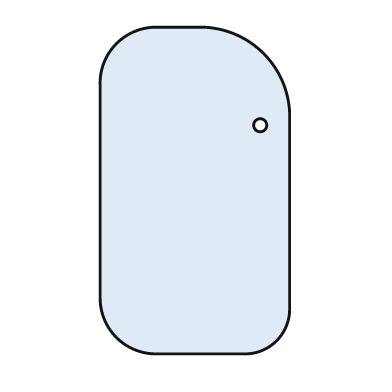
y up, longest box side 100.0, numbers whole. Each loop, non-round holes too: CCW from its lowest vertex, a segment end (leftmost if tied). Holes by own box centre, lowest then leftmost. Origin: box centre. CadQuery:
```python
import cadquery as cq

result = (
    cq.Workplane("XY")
    .moveTo(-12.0, -50.0)
    .lineTo(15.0, -50.0)
    .threePointArc((25.0, -46.0), (29.0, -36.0))
    .lineTo(29.0, 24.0)
    .threePointArc((21.0, 42.0), (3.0, 50.0))
    .lineTo(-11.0, 50.0)
    .threePointArc((-24.0, 45.0), (-29.0, 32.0))
    .lineTo(-29.0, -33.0)
    .threePointArc((-24.0, -45.0), (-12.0, -50.0))
    .close()
    .moveTo(20.0, 20.0)
    .circle(2.0)
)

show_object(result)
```